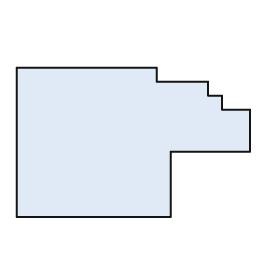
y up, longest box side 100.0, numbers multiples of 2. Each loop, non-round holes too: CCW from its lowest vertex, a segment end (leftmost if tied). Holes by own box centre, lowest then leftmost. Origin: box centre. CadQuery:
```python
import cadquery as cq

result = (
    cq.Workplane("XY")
    .moveTo(-50.0, -32.0)
    .lineTo(16.0, -32.0)
    .lineTo(16.0, -4.0)
    .lineTo(50.0, -4.0)
    .lineTo(50.0, 14.0)
    .lineTo(38.0, 14.0)
    .lineTo(38.0, 20.0)
    .lineTo(32.0, 20.0)
    .lineTo(32.0, 26.0)
    .lineTo(10.0, 26.0)
    .lineTo(10.0, 32.0)
    .lineTo(-50.0, 32.0)
    .close()
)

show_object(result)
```